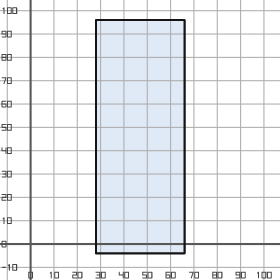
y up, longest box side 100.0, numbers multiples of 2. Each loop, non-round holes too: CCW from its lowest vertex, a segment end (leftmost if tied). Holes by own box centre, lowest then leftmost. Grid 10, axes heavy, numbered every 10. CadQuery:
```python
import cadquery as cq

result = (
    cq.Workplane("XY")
    .moveTo(28.0, -4.0)
    .lineTo(66.0, -4.0)
    .lineTo(66.0, 96.0)
    .lineTo(28.0, 96.0)
    .close()
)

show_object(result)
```